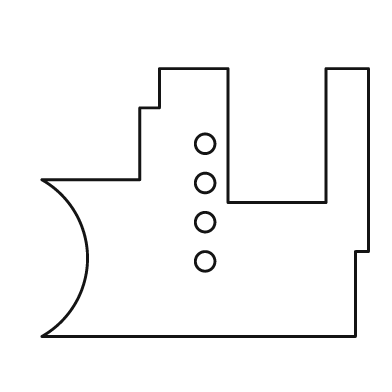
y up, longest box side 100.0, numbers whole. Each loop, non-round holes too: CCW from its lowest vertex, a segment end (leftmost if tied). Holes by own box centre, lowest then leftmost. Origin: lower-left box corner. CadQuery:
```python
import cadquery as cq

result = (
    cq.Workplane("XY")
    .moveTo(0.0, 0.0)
    .lineTo(96.0, 0.0)
    .lineTo(96.0, 26.0)
    .lineTo(100.0, 26.0)
    .lineTo(100.0, 82.0)
    .lineTo(87.0, 82.0)
    .lineTo(87.0, 41.0)
    .lineTo(57.0, 41.0)
    .lineTo(57.0, 82.0)
    .lineTo(36.0, 82.0)
    .lineTo(36.0, 70.0)
    .lineTo(30.0, 70.0)
    .lineTo(30.0, 48.0)
    .lineTo(0.0, 48.0)
    .threePointArc((14.0, 24.0), (0.0, 0.0))
    .close()
    .moveTo(50.0, 23.0)
    .circle(3.0)
    .moveTo(50.0, 35.0)
    .circle(3.0)
    .moveTo(50.0, 47.0)
    .circle(3.0)
    .moveTo(50.0, 59.0)
    .circle(3.0)
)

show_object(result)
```